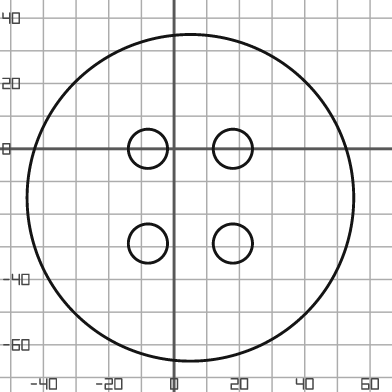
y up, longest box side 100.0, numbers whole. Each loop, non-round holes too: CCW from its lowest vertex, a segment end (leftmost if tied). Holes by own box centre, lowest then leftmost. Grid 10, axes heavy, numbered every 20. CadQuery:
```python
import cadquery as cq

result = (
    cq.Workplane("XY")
    .moveTo(5.0, -15.0)
    .circle(50.0)
    .moveTo(-8.0, -29.0)
    .circle(6.0)
    .moveTo(18.0, -29.0)
    .circle(6.0)
    .moveTo(-8.0, 0.0)
    .circle(6.0)
    .moveTo(18.0, 0.0)
    .circle(6.0)
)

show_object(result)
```